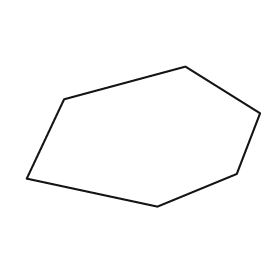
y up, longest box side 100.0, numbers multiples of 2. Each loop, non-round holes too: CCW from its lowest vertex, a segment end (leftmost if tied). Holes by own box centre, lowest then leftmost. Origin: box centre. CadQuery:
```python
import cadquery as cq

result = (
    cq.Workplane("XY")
    .moveTo(6.0, -30.0)
    .lineTo(40.0, -16.0)
    .lineTo(50.0, 10.0)
    .lineTo(18.0, 30.0)
    .lineTo(-34.0, 16.0)
    .lineTo(-50.0, -18.0)
    .close()
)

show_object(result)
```